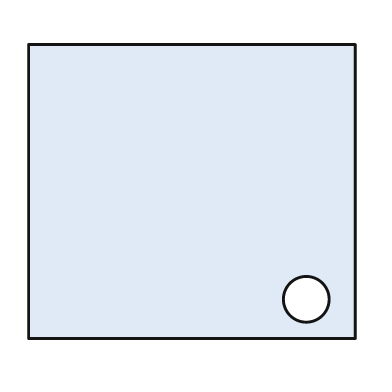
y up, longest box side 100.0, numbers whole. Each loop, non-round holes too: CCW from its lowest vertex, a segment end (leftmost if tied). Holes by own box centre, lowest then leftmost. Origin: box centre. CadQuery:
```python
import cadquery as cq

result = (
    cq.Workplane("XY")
    .moveTo(-50.0, -45.0)
    .lineTo(50.0, -45.0)
    .lineTo(50.0, 45.0)
    .lineTo(-50.0, 45.0)
    .close()
    .moveTo(35.0, -33.0)
    .circle(7.0)
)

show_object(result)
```